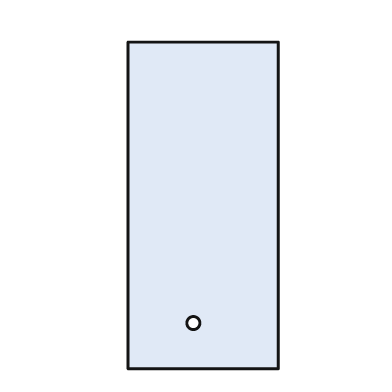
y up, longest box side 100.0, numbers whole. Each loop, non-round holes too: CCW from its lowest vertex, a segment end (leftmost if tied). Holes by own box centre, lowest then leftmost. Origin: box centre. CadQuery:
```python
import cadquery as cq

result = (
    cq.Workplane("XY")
    .moveTo(-23.0, -50.0)
    .lineTo(23.0, -50.0)
    .lineTo(23.0, 50.0)
    .lineTo(-23.0, 50.0)
    .close()
    .moveTo(-3.0, -36.0)
    .circle(2.0)
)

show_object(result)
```